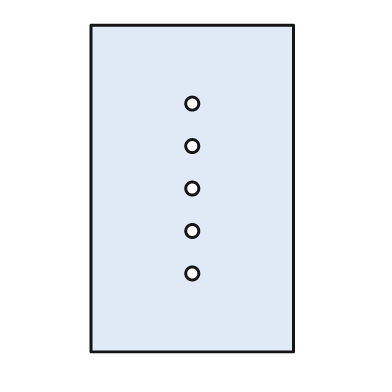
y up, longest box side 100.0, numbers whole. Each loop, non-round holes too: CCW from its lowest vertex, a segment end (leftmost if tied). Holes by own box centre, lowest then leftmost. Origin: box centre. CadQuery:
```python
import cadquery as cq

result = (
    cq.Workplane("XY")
    .moveTo(-31.0, -50.0)
    .lineTo(31.0, -50.0)
    .lineTo(31.0, 50.0)
    .lineTo(-31.0, 50.0)
    .close()
    .moveTo(0.0, -26.0)
    .circle(2.0)
    .moveTo(0.0, -13.0)
    .circle(2.0)
    .moveTo(0.0, 0.0)
    .circle(2.0)
    .moveTo(0.0, 13.0)
    .circle(2.0)
    .moveTo(0.0, 26.0)
    .circle(2.0)
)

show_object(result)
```